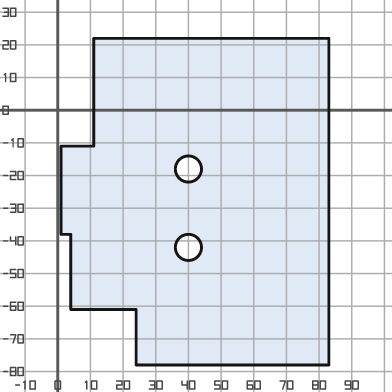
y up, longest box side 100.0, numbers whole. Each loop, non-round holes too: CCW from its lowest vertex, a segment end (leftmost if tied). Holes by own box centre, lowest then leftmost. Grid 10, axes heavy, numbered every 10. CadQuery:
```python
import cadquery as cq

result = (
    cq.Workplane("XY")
    .moveTo(24.0, -78.0)
    .lineTo(83.0, -78.0)
    .lineTo(83.0, 22.0)
    .lineTo(11.0, 22.0)
    .lineTo(11.0, -11.0)
    .lineTo(1.0, -11.0)
    .lineTo(1.0, -38.0)
    .lineTo(4.0, -38.0)
    .lineTo(4.0, -61.0)
    .lineTo(24.0, -61.0)
    .close()
    .moveTo(40.0, -42.0)
    .circle(4.0)
    .moveTo(40.0, -18.0)
    .circle(4.0)
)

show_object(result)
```